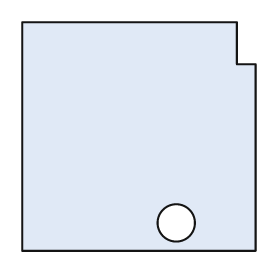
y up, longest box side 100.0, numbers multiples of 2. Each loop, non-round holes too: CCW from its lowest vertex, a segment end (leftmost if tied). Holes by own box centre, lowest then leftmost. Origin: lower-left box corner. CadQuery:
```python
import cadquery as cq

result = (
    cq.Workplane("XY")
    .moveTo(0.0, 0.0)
    .lineTo(100.0, 0.0)
    .lineTo(100.0, 80.0)
    .lineTo(92.0, 80.0)
    .lineTo(92.0, 98.0)
    .lineTo(0.0, 98.0)
    .close()
    .moveTo(66.0, 12.0)
    .circle(8.0)
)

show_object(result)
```